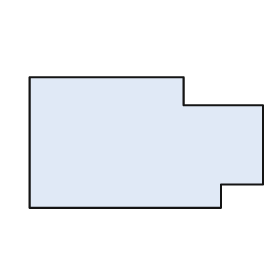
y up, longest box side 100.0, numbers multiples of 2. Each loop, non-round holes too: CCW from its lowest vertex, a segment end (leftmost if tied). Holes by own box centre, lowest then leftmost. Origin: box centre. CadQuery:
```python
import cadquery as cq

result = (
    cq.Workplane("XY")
    .moveTo(-50.0, -28.0)
    .lineTo(32.0, -28.0)
    .lineTo(32.0, -18.0)
    .lineTo(50.0, -18.0)
    .lineTo(50.0, 16.0)
    .lineTo(16.0, 16.0)
    .lineTo(16.0, 28.0)
    .lineTo(-50.0, 28.0)
    .close()
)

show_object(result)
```